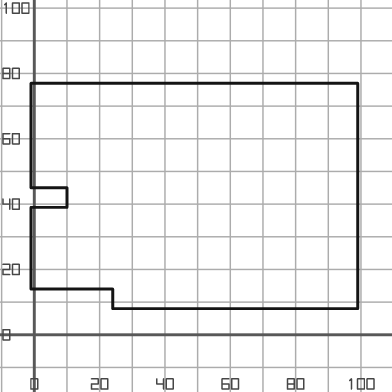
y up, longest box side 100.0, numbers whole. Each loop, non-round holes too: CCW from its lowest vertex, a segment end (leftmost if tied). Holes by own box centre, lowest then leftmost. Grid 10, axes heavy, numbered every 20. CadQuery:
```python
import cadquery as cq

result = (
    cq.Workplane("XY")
    .moveTo(24.0, 8.0)
    .lineTo(99.0, 8.0)
    .lineTo(99.0, 77.0)
    .lineTo(-1.0, 77.0)
    .lineTo(-1.0, 45.0)
    .lineTo(10.0, 45.0)
    .lineTo(10.0, 39.0)
    .lineTo(-1.0, 39.0)
    .lineTo(-1.0, 14.0)
    .lineTo(24.0, 14.0)
    .close()
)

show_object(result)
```